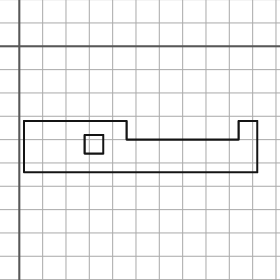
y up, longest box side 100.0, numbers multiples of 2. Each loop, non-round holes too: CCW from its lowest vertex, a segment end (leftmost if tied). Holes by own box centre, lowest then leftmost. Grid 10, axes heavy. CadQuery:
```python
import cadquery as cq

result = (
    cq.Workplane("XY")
    .moveTo(2.0, -54.0)
    .lineTo(102.0, -54.0)
    .lineTo(102.0, -32.0)
    .lineTo(94.0, -32.0)
    .lineTo(94.0, -40.0)
    .lineTo(46.0, -40.0)
    .lineTo(46.0, -32.0)
    .lineTo(2.0, -32.0)
    .close()
    .moveTo(28.0, -46.0)
    .lineTo(36.0, -46.0)
    .lineTo(36.0, -38.0)
    .lineTo(28.0, -38.0)
    .close()
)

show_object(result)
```